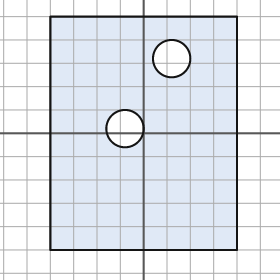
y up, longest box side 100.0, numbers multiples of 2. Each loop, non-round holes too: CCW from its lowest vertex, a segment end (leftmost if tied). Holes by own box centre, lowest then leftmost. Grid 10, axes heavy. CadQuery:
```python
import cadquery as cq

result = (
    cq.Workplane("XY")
    .moveTo(-40.0, -50.0)
    .lineTo(40.0, -50.0)
    .lineTo(40.0, 50.0)
    .lineTo(-40.0, 50.0)
    .close()
    .moveTo(-8.0, 2.0)
    .circle(8.0)
    .moveTo(12.0, 32.0)
    .circle(8.0)
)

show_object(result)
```